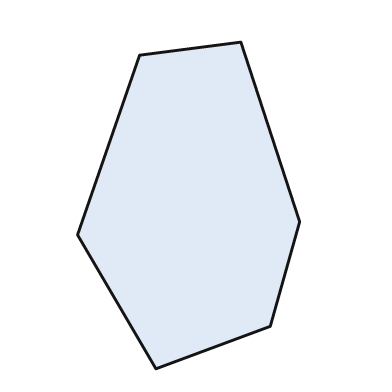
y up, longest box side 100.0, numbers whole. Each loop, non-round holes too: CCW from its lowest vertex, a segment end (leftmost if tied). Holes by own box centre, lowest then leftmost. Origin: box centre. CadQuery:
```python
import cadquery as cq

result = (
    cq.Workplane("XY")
    .moveTo(-10.0, -50.0)
    .lineTo(25.0, -37.0)
    .lineTo(34.0, -5.0)
    .lineTo(16.0, 50.0)
    .lineTo(-15.0, 46.0)
    .lineTo(-34.0, -9.0)
    .close()
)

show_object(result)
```